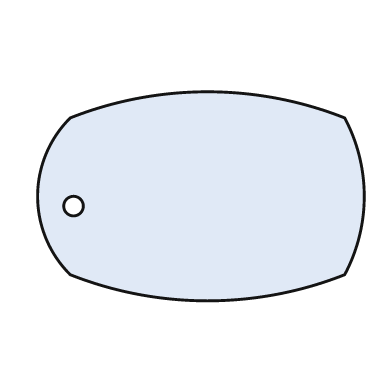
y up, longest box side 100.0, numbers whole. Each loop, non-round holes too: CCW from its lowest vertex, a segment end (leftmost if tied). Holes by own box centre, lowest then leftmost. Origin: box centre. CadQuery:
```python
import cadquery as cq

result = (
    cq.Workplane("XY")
    .moveTo(-40.0, -24.0)
    .threePointArc((2.0, -32.0), (44.0, -24.0))
    .threePointArc((50.0, 0.0), (44.0, 24.0))
    .threePointArc((2.0, 32.0), (-40.0, 24.0))
    .threePointArc((-50.0, 0.0), (-40.0, -24.0))
    .close()
    .moveTo(-39.0, -3.0)
    .circle(3.0)
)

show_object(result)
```